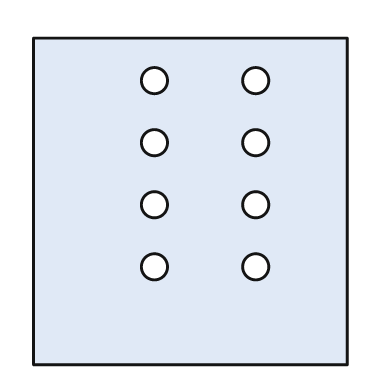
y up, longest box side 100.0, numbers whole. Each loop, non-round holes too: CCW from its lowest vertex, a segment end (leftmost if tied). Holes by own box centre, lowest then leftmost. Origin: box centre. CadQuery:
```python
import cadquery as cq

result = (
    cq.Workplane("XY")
    .moveTo(-48.0, -50.0)
    .lineTo(48.0, -50.0)
    .lineTo(48.0, 50.0)
    .lineTo(-48.0, 50.0)
    .close()
    .moveTo(-11.0, -20.0)
    .circle(4.0)
    .moveTo(20.0, -20.0)
    .circle(4.0)
    .moveTo(-11.0, -1.0)
    .circle(4.0)
    .moveTo(20.0, -1.0)
    .circle(4.0)
    .moveTo(-11.0, 18.0)
    .circle(4.0)
    .moveTo(20.0, 18.0)
    .circle(4.0)
    .moveTo(-11.0, 37.0)
    .circle(4.0)
    .moveTo(20.0, 37.0)
    .circle(4.0)
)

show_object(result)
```